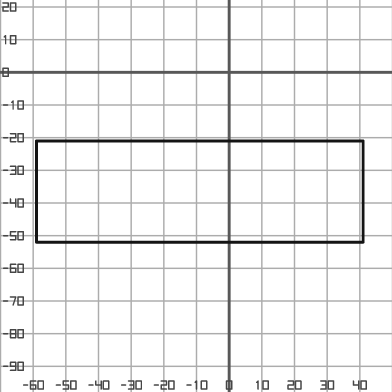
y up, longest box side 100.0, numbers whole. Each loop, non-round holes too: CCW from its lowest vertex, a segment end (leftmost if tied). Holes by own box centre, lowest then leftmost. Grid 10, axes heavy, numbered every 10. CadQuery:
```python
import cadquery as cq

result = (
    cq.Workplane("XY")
    .moveTo(-59.0, -52.0)
    .lineTo(41.0, -52.0)
    .lineTo(41.0, -21.0)
    .lineTo(-59.0, -21.0)
    .close()
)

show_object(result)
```